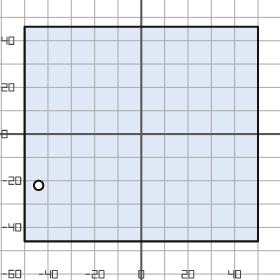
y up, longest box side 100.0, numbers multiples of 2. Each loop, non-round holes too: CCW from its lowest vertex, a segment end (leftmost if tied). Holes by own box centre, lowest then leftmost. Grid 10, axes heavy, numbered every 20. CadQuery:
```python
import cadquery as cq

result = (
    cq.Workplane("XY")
    .moveTo(-50.0, -46.0)
    .lineTo(50.0, -46.0)
    .lineTo(50.0, 46.0)
    .lineTo(-50.0, 46.0)
    .close()
    .moveTo(-44.0, -22.0)
    .circle(2.0)
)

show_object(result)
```